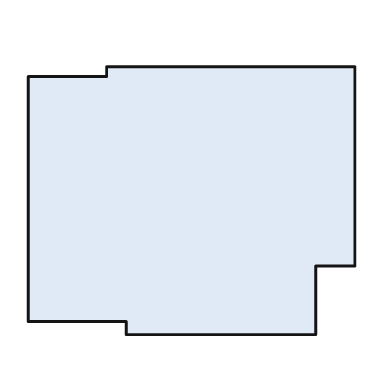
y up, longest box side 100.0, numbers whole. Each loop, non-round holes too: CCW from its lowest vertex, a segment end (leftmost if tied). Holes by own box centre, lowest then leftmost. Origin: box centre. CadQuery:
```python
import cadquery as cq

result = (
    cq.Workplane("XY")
    .moveTo(-20.0, -41.0)
    .lineTo(38.0, -41.0)
    .lineTo(38.0, -20.0)
    .lineTo(50.0, -20.0)
    .lineTo(50.0, 41.0)
    .lineTo(-26.0, 41.0)
    .lineTo(-26.0, 38.0)
    .lineTo(-50.0, 38.0)
    .lineTo(-50.0, -37.0)
    .lineTo(-20.0, -37.0)
    .close()
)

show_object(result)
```